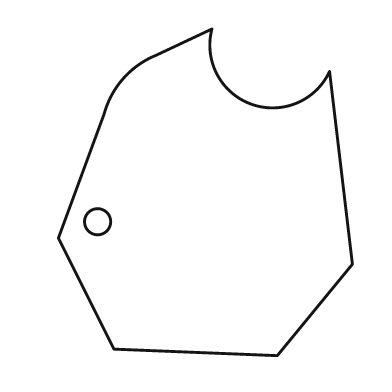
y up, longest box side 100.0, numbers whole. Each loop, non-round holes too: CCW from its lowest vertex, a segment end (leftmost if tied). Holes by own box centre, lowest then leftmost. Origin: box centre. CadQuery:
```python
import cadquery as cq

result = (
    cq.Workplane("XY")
    .moveTo(22.0, -50.0)
    .lineTo(45.0, -22.0)
    .lineTo(38.0, 37.0)
    .threePointArc((14.0, 27.0), (2.0, 50.0))
    .lineTo(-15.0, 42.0)
    .threePointArc((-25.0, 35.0), (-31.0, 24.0))
    .lineTo(-45.0, -14.0)
    .lineTo(-28.0, -48.0)
    .close()
    .moveTo(-33.0, -9.0)
    .circle(4.0)
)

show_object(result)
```